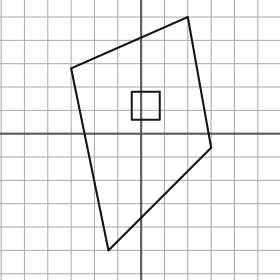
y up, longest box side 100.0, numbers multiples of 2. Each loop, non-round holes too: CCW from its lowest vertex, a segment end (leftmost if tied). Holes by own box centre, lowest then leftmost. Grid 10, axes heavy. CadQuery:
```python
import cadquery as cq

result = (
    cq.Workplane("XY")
    .moveTo(-14.0, -50.0)
    .lineTo(30.0, -6.0)
    .lineTo(20.0, 50.0)
    .lineTo(-30.0, 28.0)
    .close()
    .moveTo(-4.0, 6.0)
    .lineTo(8.0, 6.0)
    .lineTo(8.0, 18.0)
    .lineTo(-4.0, 18.0)
    .close()
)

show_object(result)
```